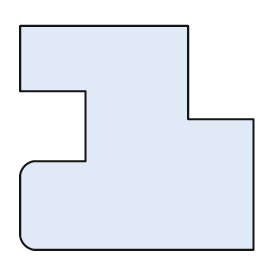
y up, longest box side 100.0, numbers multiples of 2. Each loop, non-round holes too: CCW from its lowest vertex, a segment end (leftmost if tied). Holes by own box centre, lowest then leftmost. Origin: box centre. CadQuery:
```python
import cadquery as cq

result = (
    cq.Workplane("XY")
    .moveTo(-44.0, -48.0)
    .lineTo(50.0, -48.0)
    .lineTo(50.0, 8.0)
    .lineTo(22.0, 8.0)
    .lineTo(22.0, 48.0)
    .lineTo(-50.0, 48.0)
    .lineTo(-50.0, 20.0)
    .lineTo(-22.0, 20.0)
    .lineTo(-22.0, -10.0)
    .lineTo(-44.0, -10.0)
    .threePointArc((-48.0, -12.0), (-50.0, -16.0))
    .lineTo(-50.0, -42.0)
    .threePointArc((-48.0, -46.0), (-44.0, -48.0))
    .close()
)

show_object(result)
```